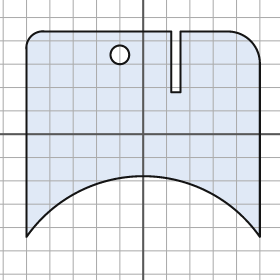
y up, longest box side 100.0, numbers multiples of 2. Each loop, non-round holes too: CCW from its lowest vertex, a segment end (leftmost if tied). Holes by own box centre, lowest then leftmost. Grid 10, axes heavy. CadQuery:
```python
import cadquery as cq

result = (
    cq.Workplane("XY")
    .moveTo(-50.0, -44.0)
    .threePointArc((0.0, -18.0), (50.0, -44.0))
    .lineTo(50.0, 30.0)
    .threePointArc((46.0, 40.0), (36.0, 44.0))
    .lineTo(16.0, 44.0)
    .lineTo(16.0, 18.0)
    .lineTo(12.0, 18.0)
    .lineTo(12.0, 44.0)
    .lineTo(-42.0, 44.0)
    .threePointArc((-48.0, 42.0), (-50.0, 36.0))
    .close()
    .moveTo(-10.0, 34.0)
    .circle(4.0)
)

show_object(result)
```